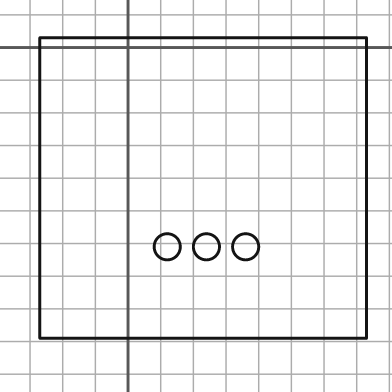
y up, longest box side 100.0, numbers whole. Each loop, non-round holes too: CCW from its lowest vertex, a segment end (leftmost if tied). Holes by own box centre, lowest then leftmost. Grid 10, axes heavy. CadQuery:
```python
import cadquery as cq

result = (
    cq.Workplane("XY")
    .moveTo(-27.0, -89.0)
    .lineTo(73.0, -89.0)
    .lineTo(73.0, 3.0)
    .lineTo(-27.0, 3.0)
    .close()
    .moveTo(12.0, -61.0)
    .circle(4.0)
    .moveTo(24.0, -61.0)
    .circle(4.0)
    .moveTo(36.0, -61.0)
    .circle(4.0)
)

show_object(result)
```